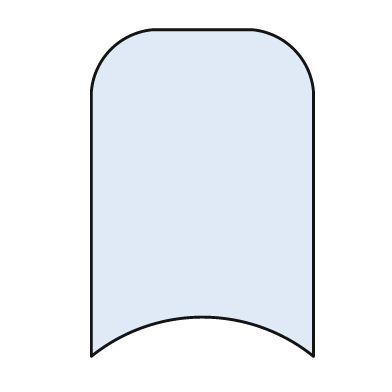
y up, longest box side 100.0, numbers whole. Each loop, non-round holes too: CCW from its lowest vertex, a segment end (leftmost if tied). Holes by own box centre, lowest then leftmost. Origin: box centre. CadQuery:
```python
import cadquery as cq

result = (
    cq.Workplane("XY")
    .moveTo(-34.0, -50.0)
    .threePointArc((0.0, -38.0), (34.0, -50.0))
    .lineTo(34.0, 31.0)
    .threePointArc((28.0, 44.0), (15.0, 50.0))
    .lineTo(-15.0, 50.0)
    .threePointArc((-28.0, 44.0), (-34.0, 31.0))
    .close()
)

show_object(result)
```